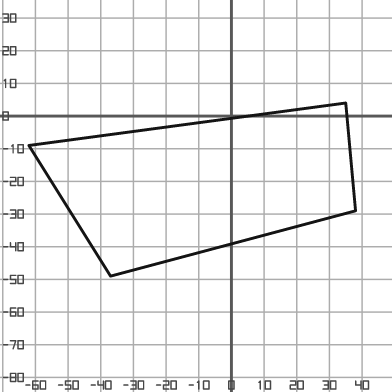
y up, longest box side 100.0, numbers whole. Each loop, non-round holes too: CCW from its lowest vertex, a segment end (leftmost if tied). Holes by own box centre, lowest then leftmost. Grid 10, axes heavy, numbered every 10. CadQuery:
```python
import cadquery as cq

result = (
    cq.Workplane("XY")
    .moveTo(-37.0, -49.0)
    .lineTo(38.0, -29.0)
    .lineTo(35.0, 4.0)
    .lineTo(-62.0, -9.0)
    .close()
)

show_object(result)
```